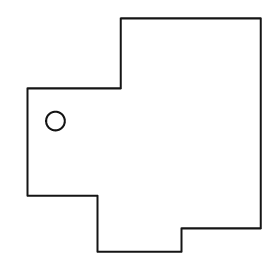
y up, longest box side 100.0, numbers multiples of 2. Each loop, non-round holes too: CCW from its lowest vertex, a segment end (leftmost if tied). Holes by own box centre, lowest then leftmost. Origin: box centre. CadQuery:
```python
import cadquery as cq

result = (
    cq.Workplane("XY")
    .moveTo(-20.0, -50.0)
    .lineTo(16.0, -50.0)
    .lineTo(16.0, -40.0)
    .lineTo(50.0, -40.0)
    .lineTo(50.0, 50.0)
    .lineTo(-10.0, 50.0)
    .lineTo(-10.0, 20.0)
    .lineTo(-50.0, 20.0)
    .lineTo(-50.0, -26.0)
    .lineTo(-20.0, -26.0)
    .close()
    .moveTo(-38.0, 6.0)
    .circle(4.0)
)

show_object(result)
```